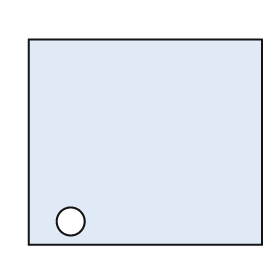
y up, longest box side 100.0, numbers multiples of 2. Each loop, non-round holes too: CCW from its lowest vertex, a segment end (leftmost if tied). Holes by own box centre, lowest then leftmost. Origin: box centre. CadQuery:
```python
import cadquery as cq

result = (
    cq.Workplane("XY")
    .moveTo(-50.0, -44.0)
    .lineTo(50.0, -44.0)
    .lineTo(50.0, 44.0)
    .lineTo(-50.0, 44.0)
    .close()
    .moveTo(-32.0, -34.0)
    .circle(6.0)
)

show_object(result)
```